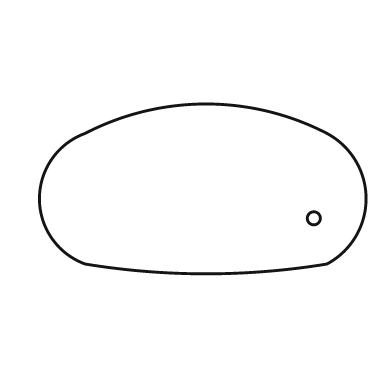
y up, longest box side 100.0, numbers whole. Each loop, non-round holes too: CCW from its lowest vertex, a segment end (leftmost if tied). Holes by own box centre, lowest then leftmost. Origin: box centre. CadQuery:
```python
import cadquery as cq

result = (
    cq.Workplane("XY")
    .moveTo(-36.0, -23.0)
    .threePointArc((1.0, -26.0), (38.0, -23.0))
    .threePointArc((50.0, -3.0), (38.0, 17.0))
    .threePointArc((1.0, 26.0), (-36.0, 17.0))
    .threePointArc((-50.0, -3.0), (-36.0, -23.0))
    .close()
    .moveTo(34.0, -9.0)
    .circle(2.0)
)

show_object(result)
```